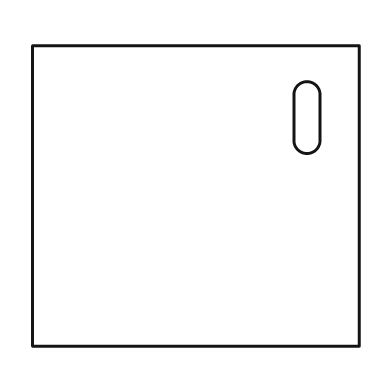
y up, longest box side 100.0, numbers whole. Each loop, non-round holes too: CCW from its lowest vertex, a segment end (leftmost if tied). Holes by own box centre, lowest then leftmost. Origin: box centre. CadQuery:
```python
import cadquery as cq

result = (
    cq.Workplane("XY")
    .moveTo(-50.0, -46.0)
    .lineTo(50.0, -46.0)
    .lineTo(50.0, 46.0)
    .lineTo(-50.0, 46.0)
    .close()
    .moveTo(30.0, 17.0)
    .threePointArc((34.0, 13.0), (38.0, 17.0))
    .lineTo(38.0, 31.0)
    .threePointArc((34.0, 35.0), (30.0, 31.0))
    .close()
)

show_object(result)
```